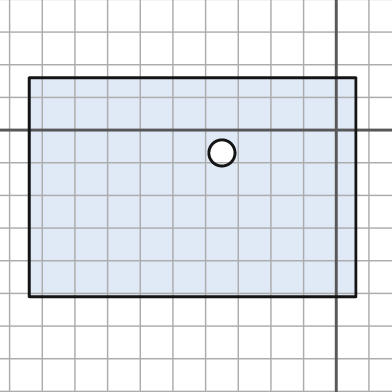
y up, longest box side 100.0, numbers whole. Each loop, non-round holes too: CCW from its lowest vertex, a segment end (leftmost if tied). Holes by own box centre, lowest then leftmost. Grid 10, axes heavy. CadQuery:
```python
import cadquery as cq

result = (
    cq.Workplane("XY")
    .moveTo(-94.0, -51.0)
    .lineTo(6.0, -51.0)
    .lineTo(6.0, 16.0)
    .lineTo(-94.0, 16.0)
    .close()
    .moveTo(-35.0, -7.0)
    .circle(4.0)
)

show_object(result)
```